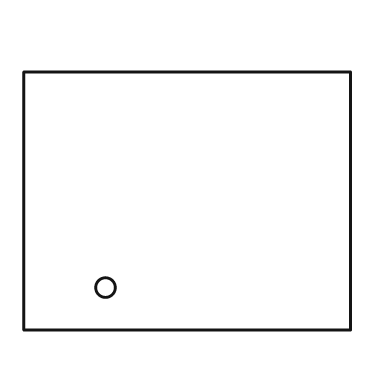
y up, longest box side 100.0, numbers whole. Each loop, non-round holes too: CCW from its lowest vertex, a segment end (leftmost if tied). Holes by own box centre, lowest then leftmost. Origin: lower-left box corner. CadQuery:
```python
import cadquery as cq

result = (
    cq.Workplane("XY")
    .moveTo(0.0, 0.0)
    .lineTo(100.0, 0.0)
    .lineTo(100.0, 79.0)
    .lineTo(0.0, 79.0)
    .close()
    .moveTo(25.0, 13.0)
    .circle(3.0)
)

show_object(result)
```